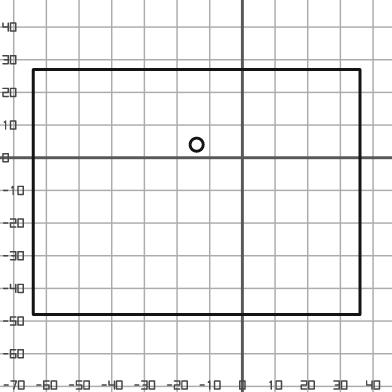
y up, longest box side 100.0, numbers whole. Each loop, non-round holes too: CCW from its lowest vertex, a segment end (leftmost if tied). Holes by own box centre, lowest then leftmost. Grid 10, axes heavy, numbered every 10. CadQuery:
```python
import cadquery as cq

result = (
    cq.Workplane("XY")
    .moveTo(-64.0, -48.0)
    .lineTo(36.0, -48.0)
    .lineTo(36.0, 27.0)
    .lineTo(-64.0, 27.0)
    .close()
    .moveTo(-14.0, 4.0)
    .circle(2.0)
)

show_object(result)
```